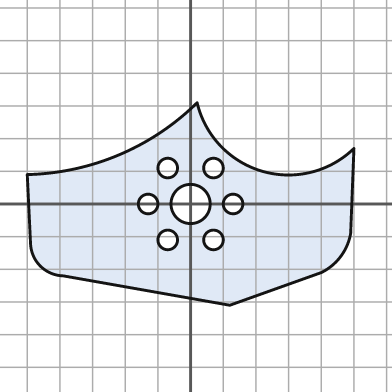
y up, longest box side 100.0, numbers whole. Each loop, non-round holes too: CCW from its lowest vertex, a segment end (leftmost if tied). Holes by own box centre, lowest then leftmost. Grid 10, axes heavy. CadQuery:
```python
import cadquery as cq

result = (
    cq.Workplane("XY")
    .moveTo(12.0, -31.0)
    .lineTo(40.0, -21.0)
    .threePointArc((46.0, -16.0), (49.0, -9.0))
    .lineTo(50.0, 17.0)
    .threePointArc((22.0, 10.0), (2.0, 31.0))
    .threePointArc((-22.0, 15.0), (-50.0, 9.0))
    .lineTo(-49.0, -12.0)
    .threePointArc((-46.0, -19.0), (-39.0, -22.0))
    .close()
    .moveTo(-7.0, -11.0)
    .circle(3.0)
    .moveTo(7.0, -11.0)
    .circle(3.0)
    .moveTo(-13.0, 0.0)
    .circle(3.0)
    .moveTo(0.0, 0.0)
    .circle(6.0)
    .moveTo(13.0, 0.0)
    .circle(3.0)
    .moveTo(-7.0, 11.0)
    .circle(3.0)
    .moveTo(7.0, 11.0)
    .circle(3.0)
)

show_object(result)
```